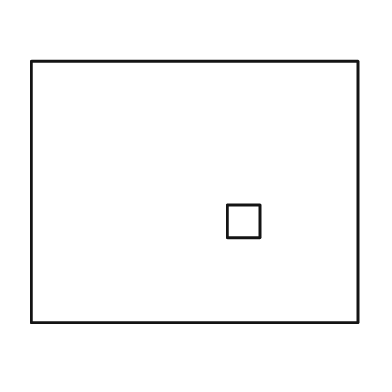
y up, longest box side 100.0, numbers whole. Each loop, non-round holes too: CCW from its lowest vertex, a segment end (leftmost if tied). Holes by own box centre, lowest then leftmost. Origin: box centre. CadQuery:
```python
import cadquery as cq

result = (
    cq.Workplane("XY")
    .moveTo(-50.0, -40.0)
    .lineTo(50.0, -40.0)
    .lineTo(50.0, 40.0)
    .lineTo(-50.0, 40.0)
    .close()
    .moveTo(10.0, -14.0)
    .lineTo(20.0, -14.0)
    .lineTo(20.0, -4.0)
    .lineTo(10.0, -4.0)
    .close()
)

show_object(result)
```